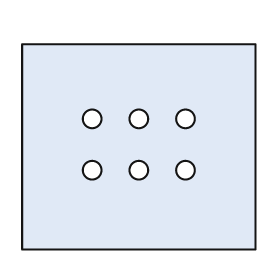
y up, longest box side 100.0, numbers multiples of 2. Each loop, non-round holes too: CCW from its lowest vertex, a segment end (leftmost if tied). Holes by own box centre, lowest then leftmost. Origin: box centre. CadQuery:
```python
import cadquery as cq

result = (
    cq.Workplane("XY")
    .moveTo(-50.0, -44.0)
    .lineTo(50.0, -44.0)
    .lineTo(50.0, 44.0)
    .lineTo(-50.0, 44.0)
    .close()
    .moveTo(-20.0, -10.0)
    .circle(4.0)
    .moveTo(0.0, -10.0)
    .circle(4.0)
    .moveTo(20.0, -10.0)
    .circle(4.0)
    .moveTo(-20.0, 12.0)
    .circle(4.0)
    .moveTo(0.0, 12.0)
    .circle(4.0)
    .moveTo(20.0, 12.0)
    .circle(4.0)
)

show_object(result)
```